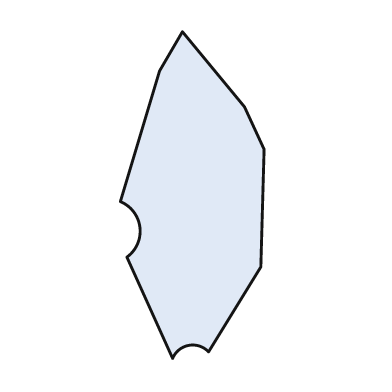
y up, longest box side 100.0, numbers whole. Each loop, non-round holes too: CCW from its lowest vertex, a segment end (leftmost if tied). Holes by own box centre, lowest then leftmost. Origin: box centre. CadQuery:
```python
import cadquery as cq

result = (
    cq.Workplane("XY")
    .moveTo(-6.0, -50.0)
    .threePointArc((-1.0, -46.0), (5.0, -48.0))
    .lineTo(21.0, -22.0)
    .lineTo(22.0, 14.0)
    .lineTo(16.0, 27.0)
    .lineTo(-3.0, 50.0)
    .lineTo(-10.0, 38.0)
    .lineTo(-22.0, -2.0)
    .threePointArc((-16.0, -10.0), (-20.0, -19.0))
    .close()
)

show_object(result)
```